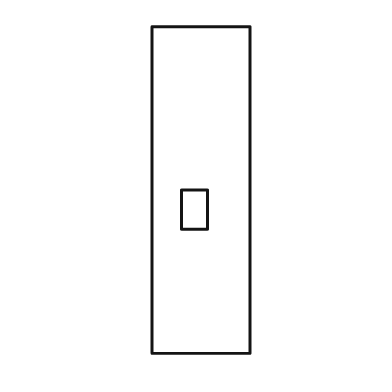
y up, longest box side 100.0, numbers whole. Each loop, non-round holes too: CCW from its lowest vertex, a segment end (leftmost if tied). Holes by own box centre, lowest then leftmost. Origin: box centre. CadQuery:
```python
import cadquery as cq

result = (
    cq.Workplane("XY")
    .moveTo(-15.0, -50.0)
    .lineTo(15.0, -50.0)
    .lineTo(15.0, 50.0)
    .lineTo(-15.0, 50.0)
    .close()
    .moveTo(-6.0, -12.0)
    .lineTo(2.0, -12.0)
    .lineTo(2.0, 0.0)
    .lineTo(-6.0, 0.0)
    .close()
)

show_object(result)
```